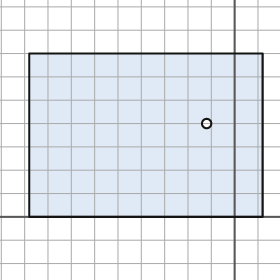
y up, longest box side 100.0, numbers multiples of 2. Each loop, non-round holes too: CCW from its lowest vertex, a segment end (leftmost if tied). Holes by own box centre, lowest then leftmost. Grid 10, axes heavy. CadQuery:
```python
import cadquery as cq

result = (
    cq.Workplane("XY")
    .moveTo(-88.0, 0.0)
    .lineTo(12.0, 0.0)
    .lineTo(12.0, 70.0)
    .lineTo(-88.0, 70.0)
    .close()
    .moveTo(-12.0, 40.0)
    .circle(2.0)
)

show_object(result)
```